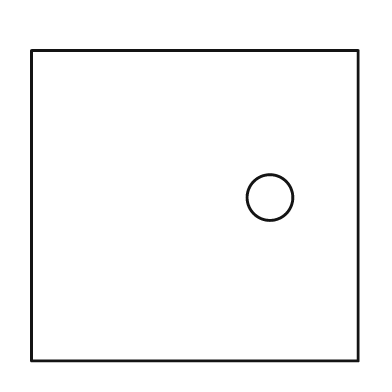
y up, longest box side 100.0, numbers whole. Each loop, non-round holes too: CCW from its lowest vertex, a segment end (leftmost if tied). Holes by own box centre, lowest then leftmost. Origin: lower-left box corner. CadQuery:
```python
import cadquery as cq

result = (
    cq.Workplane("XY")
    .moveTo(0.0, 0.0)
    .lineTo(100.0, 0.0)
    .lineTo(100.0, 95.0)
    .lineTo(0.0, 95.0)
    .close()
    .moveTo(73.0, 50.0)
    .circle(7.0)
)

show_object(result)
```